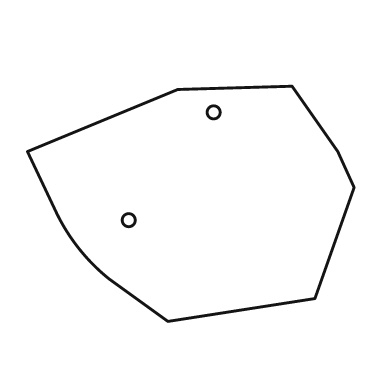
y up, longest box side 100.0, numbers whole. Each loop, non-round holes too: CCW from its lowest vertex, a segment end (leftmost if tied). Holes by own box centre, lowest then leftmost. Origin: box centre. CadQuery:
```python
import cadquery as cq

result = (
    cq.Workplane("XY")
    .moveTo(-7.0, -36.0)
    .lineTo(38.0, -29.0)
    .lineTo(50.0, 5.0)
    .lineTo(45.0, 16.0)
    .lineTo(31.0, 36.0)
    .lineTo(-4.0, 35.0)
    .lineTo(-50.0, 16.0)
    .lineTo(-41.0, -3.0)
    .threePointArc((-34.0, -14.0), (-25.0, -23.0))
    .close()
    .moveTo(-19.0, -5.0)
    .circle(2.0)
    .moveTo(7.0, 28.0)
    .circle(2.0)
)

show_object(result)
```